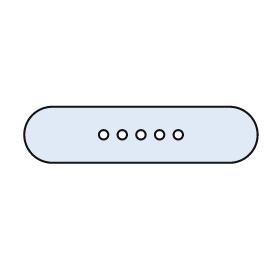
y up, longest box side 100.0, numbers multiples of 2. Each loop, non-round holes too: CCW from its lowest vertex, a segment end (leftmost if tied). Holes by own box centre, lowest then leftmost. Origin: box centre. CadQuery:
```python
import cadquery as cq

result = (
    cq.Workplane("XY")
    .moveTo(-38.0, -12.0)
    .lineTo(38.0, -12.0)
    .threePointArc((50.0, 0.0), (38.0, 12.0))
    .lineTo(-38.0, 12.0)
    .threePointArc((-50.0, 0.0), (-38.0, -12.0))
    .close()
    .moveTo(-16.0, 0.0)
    .circle(2.0)
    .moveTo(-8.0, 0.0)
    .circle(2.0)
    .moveTo(0.0, 0.0)
    .circle(2.0)
    .moveTo(8.0, 0.0)
    .circle(2.0)
    .moveTo(16.0, 0.0)
    .circle(2.0)
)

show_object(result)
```